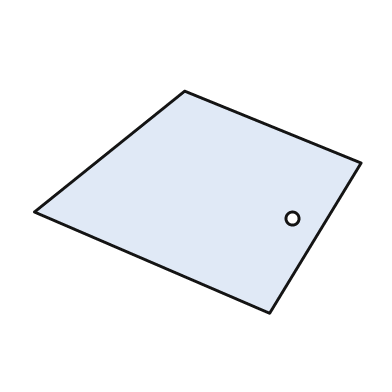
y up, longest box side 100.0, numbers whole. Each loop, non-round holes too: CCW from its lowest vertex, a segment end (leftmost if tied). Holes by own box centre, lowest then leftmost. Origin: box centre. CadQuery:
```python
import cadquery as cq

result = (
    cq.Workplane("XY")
    .moveTo(22.0, -34.0)
    .lineTo(50.0, 12.0)
    .lineTo(-4.0, 34.0)
    .lineTo(-50.0, -3.0)
    .close()
    .moveTo(29.0, -5.0)
    .circle(2.0)
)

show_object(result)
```